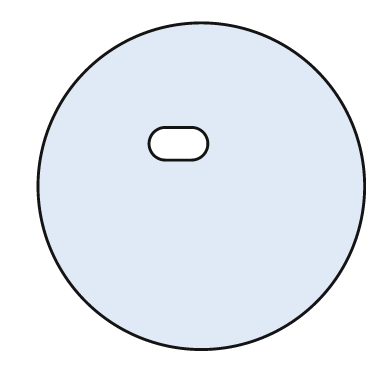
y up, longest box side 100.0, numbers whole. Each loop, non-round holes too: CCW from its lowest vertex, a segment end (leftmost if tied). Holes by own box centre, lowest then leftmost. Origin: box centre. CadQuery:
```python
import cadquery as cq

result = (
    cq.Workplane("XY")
    .moveTo(0.0, 0.0)
    .circle(50.0)
    .moveTo(-11.0, 8.0)
    .lineTo(-3.0, 8.0)
    .threePointArc((2.0, 13.0), (-3.0, 18.0))
    .lineTo(-11.0, 18.0)
    .threePointArc((-16.0, 13.0), (-11.0, 8.0))
    .close()
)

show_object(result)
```